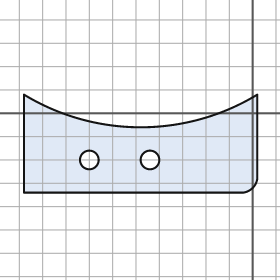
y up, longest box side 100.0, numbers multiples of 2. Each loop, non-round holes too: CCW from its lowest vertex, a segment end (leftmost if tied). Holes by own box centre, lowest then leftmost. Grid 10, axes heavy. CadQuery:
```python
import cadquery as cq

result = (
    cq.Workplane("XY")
    .moveTo(-98.0, -34.0)
    .lineTo(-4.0, -34.0)
    .threePointArc((0.0, -32.0), (2.0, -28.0))
    .lineTo(2.0, 8.0)
    .threePointArc((-48.0, -6.0), (-98.0, 8.0))
    .close()
    .moveTo(-70.0, -20.0)
    .circle(4.0)
    .moveTo(-44.0, -20.0)
    .circle(4.0)
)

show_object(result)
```